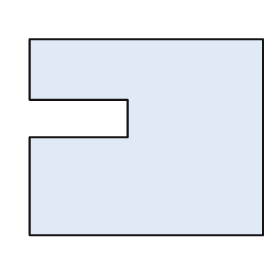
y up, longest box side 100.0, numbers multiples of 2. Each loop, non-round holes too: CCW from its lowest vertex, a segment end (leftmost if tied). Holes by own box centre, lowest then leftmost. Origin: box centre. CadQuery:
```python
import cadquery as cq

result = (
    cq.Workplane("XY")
    .moveTo(-50.0, -42.0)
    .lineTo(50.0, -42.0)
    .lineTo(50.0, 42.0)
    .lineTo(-50.0, 42.0)
    .lineTo(-50.0, 16.0)
    .lineTo(-8.0, 16.0)
    .lineTo(-8.0, 0.0)
    .lineTo(-50.0, 0.0)
    .close()
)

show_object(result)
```